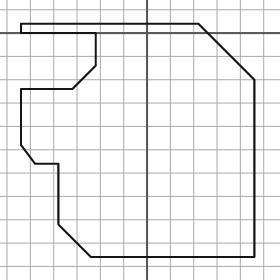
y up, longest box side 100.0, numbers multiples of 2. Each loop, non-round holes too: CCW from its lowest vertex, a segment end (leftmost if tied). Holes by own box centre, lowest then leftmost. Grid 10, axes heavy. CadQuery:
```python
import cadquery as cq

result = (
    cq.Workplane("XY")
    .moveTo(-24.0, -96.0)
    .lineTo(46.0, -96.0)
    .lineTo(46.0, -20.0)
    .lineTo(22.0, 4.0)
    .lineTo(-54.0, 4.0)
    .lineTo(-54.0, 0.0)
    .lineTo(-22.0, 0.0)
    .lineTo(-22.0, -14.0)
    .lineTo(-32.0, -24.0)
    .lineTo(-54.0, -24.0)
    .lineTo(-54.0, -48.0)
    .lineTo(-48.0, -56.0)
    .lineTo(-38.0, -56.0)
    .lineTo(-38.0, -82.0)
    .close()
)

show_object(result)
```